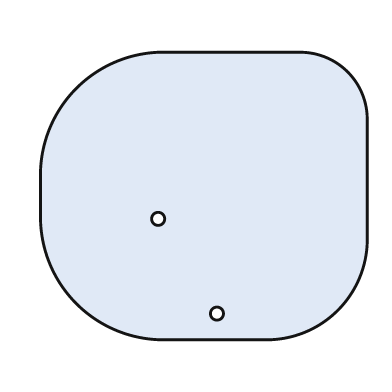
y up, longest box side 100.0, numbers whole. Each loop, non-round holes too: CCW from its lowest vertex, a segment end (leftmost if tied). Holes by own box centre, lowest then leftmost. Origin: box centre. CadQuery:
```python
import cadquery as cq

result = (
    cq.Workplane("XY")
    .moveTo(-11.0, -44.0)
    .lineTo(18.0, -44.0)
    .threePointArc((41.0, -35.0), (50.0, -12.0))
    .lineTo(50.0, 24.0)
    .threePointArc((44.0, 38.0), (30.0, 44.0))
    .lineTo(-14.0, 44.0)
    .threePointArc((-39.0, 33.0), (-50.0, 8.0))
    .lineTo(-50.0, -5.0)
    .threePointArc((-39.0, -33.0), (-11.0, -44.0))
    .close()
    .moveTo(4.0, -36.0)
    .circle(2.0)
    .moveTo(-14.0, -7.0)
    .circle(2.0)
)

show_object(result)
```